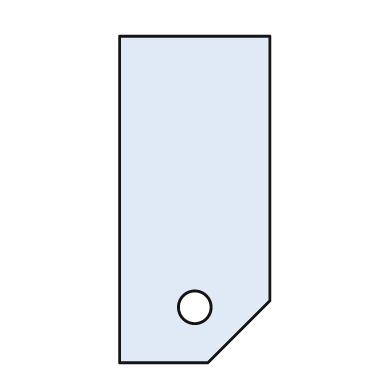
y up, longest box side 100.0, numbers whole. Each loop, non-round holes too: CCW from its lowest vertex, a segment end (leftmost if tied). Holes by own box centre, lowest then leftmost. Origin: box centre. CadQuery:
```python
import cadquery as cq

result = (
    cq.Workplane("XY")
    .moveTo(-23.0, -50.0)
    .lineTo(4.0, -50.0)
    .lineTo(23.0, -31.0)
    .lineTo(23.0, 50.0)
    .lineTo(-23.0, 50.0)
    .close()
    .moveTo(0.0, -33.0)
    .circle(5.0)
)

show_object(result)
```